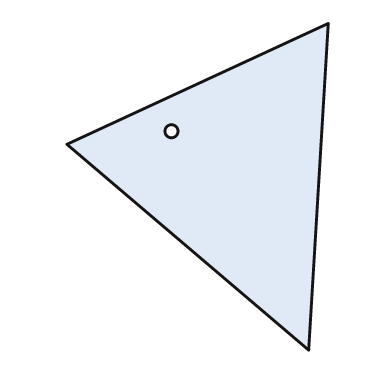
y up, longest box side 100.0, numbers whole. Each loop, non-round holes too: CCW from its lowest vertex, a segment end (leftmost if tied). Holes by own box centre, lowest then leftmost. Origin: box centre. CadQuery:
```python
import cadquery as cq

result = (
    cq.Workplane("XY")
    .moveTo(34.0, -50.0)
    .lineTo(40.0, 50.0)
    .lineTo(-40.0, 13.0)
    .close()
    .moveTo(-8.0, 17.0)
    .circle(2.0)
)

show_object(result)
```